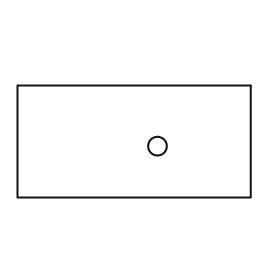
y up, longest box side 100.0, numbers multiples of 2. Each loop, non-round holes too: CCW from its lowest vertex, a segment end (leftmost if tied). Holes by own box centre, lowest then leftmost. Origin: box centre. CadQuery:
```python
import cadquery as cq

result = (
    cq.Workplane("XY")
    .moveTo(-50.0, -24.0)
    .lineTo(50.0, -24.0)
    .lineTo(50.0, 24.0)
    .lineTo(-50.0, 24.0)
    .close()
    .moveTo(10.0, -2.0)
    .circle(4.0)
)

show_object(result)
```